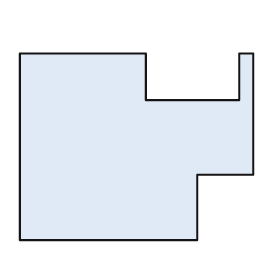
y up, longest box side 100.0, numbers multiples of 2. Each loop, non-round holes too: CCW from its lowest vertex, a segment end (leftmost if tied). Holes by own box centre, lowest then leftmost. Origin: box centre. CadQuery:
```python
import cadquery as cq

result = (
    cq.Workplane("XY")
    .moveTo(-50.0, -40.0)
    .lineTo(26.0, -40.0)
    .lineTo(26.0, -12.0)
    .lineTo(50.0, -12.0)
    .lineTo(50.0, 40.0)
    .lineTo(44.0, 40.0)
    .lineTo(44.0, 20.0)
    .lineTo(4.0, 20.0)
    .lineTo(4.0, 40.0)
    .lineTo(-50.0, 40.0)
    .close()
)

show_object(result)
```